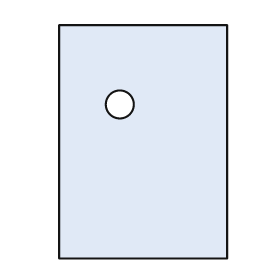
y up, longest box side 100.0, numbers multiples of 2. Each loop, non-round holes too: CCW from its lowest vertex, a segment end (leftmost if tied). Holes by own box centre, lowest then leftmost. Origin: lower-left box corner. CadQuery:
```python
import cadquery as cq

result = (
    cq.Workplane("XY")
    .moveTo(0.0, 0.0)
    .lineTo(72.0, 0.0)
    .lineTo(72.0, 100.0)
    .lineTo(0.0, 100.0)
    .close()
    .moveTo(26.0, 66.0)
    .circle(6.0)
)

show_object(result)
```